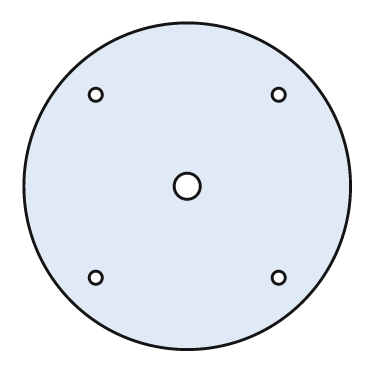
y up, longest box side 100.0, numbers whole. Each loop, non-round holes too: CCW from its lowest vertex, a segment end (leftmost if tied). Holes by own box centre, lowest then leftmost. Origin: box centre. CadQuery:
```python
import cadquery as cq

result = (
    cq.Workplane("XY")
    .moveTo(0.0, 0.0)
    .circle(50.0)
    .moveTo(-28.0, -28.0)
    .circle(2.0)
    .moveTo(28.0, -28.0)
    .circle(2.0)
    .moveTo(0.0, 0.0)
    .circle(4.0)
    .moveTo(-28.0, 28.0)
    .circle(2.0)
    .moveTo(28.0, 28.0)
    .circle(2.0)
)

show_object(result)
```